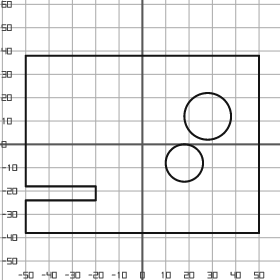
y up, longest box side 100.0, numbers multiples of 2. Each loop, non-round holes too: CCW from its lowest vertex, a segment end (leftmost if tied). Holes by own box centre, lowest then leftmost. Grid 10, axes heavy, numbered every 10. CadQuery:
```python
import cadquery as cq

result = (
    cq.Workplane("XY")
    .moveTo(-50.0, -38.0)
    .lineTo(50.0, -38.0)
    .lineTo(50.0, 38.0)
    .lineTo(-50.0, 38.0)
    .lineTo(-50.0, -18.0)
    .lineTo(-20.0, -18.0)
    .lineTo(-20.0, -24.0)
    .lineTo(-50.0, -24.0)
    .close()
    .moveTo(18.0, -8.0)
    .circle(8.0)
    .moveTo(28.0, 12.0)
    .circle(10.0)
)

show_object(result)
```